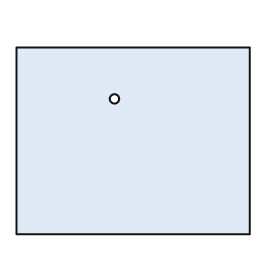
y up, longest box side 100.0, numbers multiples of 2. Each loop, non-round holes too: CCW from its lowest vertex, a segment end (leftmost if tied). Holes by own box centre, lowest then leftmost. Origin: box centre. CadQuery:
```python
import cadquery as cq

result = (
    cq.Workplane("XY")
    .moveTo(-50.0, -40.0)
    .lineTo(50.0, -40.0)
    .lineTo(50.0, 40.0)
    .lineTo(-50.0, 40.0)
    .close()
    .moveTo(-8.0, 18.0)
    .circle(2.0)
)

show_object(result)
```